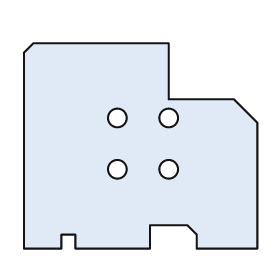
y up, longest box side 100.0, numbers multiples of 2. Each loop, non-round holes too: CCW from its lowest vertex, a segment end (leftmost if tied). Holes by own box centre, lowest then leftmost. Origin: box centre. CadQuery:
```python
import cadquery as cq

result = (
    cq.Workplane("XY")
    .moveTo(-50.0, -44.0)
    .lineTo(-34.0, -44.0)
    .lineTo(-34.0, -38.0)
    .lineTo(-28.0, -38.0)
    .lineTo(-28.0, -44.0)
    .lineTo(4.0, -44.0)
    .lineTo(4.0, -34.0)
    .lineTo(20.0, -34.0)
    .lineTo(24.0, -38.0)
    .lineTo(24.0, -44.0)
    .lineTo(50.0, -44.0)
    .lineTo(50.0, 10.0)
    .lineTo(40.0, 20.0)
    .lineTo(12.0, 20.0)
    .lineTo(12.0, 44.0)
    .lineTo(-46.0, 44.0)
    .lineTo(-50.0, 40.0)
    .close()
    .moveTo(-10.0, -10.0)
    .circle(4.0)
    .moveTo(12.0, -10.0)
    .circle(4.0)
    .moveTo(-10.0, 12.0)
    .circle(4.0)
    .moveTo(12.0, 12.0)
    .circle(4.0)
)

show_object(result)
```